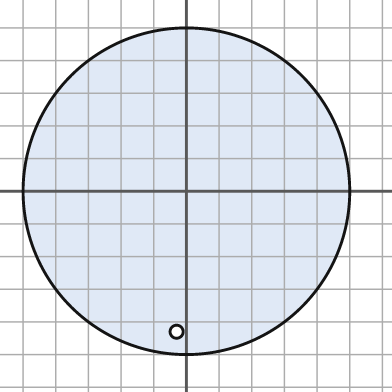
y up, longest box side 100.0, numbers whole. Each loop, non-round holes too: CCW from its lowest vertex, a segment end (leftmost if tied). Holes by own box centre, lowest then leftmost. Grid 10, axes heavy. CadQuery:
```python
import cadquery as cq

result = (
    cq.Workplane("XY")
    .moveTo(0.0, 0.0)
    .circle(50.0)
    .moveTo(-3.0, -43.0)
    .circle(2.0)
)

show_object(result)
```